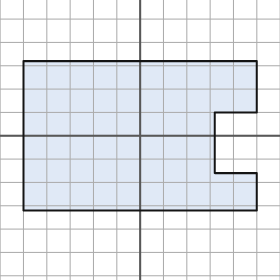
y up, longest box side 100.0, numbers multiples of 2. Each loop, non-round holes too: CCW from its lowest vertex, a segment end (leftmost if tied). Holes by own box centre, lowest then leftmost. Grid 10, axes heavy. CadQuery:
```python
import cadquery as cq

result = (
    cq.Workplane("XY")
    .moveTo(-50.0, -32.0)
    .lineTo(50.0, -32.0)
    .lineTo(50.0, -16.0)
    .lineTo(32.0, -16.0)
    .lineTo(32.0, 10.0)
    .lineTo(50.0, 10.0)
    .lineTo(50.0, 32.0)
    .lineTo(-50.0, 32.0)
    .close()
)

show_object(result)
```